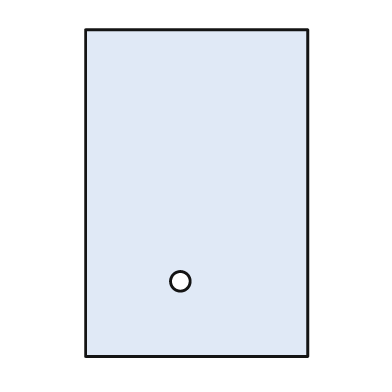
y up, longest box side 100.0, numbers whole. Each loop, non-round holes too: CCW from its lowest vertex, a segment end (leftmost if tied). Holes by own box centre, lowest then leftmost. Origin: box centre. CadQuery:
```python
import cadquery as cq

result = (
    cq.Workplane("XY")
    .moveTo(-34.0, -50.0)
    .lineTo(34.0, -50.0)
    .lineTo(34.0, 50.0)
    .lineTo(-34.0, 50.0)
    .close()
    .moveTo(-5.0, -27.0)
    .circle(3.0)
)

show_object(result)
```